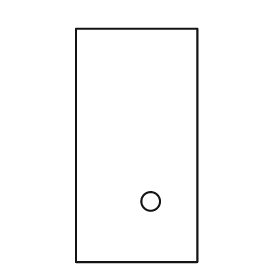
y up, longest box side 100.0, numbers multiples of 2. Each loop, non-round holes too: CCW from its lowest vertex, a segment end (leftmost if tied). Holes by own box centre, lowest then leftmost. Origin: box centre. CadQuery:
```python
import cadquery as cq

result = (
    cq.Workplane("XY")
    .moveTo(-26.0, -50.0)
    .lineTo(26.0, -50.0)
    .lineTo(26.0, 50.0)
    .lineTo(-26.0, 50.0)
    .close()
    .moveTo(6.0, -24.0)
    .circle(4.0)
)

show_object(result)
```